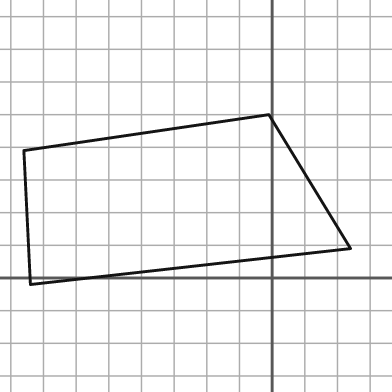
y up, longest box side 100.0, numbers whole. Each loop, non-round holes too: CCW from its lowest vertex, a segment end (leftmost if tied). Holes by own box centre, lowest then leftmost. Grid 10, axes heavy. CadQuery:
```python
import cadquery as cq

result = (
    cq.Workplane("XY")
    .moveTo(-74.0, -2.0)
    .lineTo(24.0, 9.0)
    .lineTo(-1.0, 50.0)
    .lineTo(-76.0, 39.0)
    .close()
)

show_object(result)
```